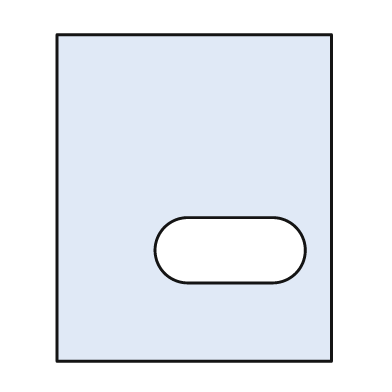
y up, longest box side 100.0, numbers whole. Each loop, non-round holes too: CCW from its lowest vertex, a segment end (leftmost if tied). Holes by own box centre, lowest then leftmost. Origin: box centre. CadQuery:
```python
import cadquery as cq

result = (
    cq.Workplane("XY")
    .moveTo(-42.0, -50.0)
    .lineTo(42.0, -50.0)
    .lineTo(42.0, 50.0)
    .lineTo(-42.0, 50.0)
    .close()
    .moveTo(-2.0, -26.0)
    .lineTo(24.0, -26.0)
    .threePointArc((34.0, -16.0), (24.0, -6.0))
    .lineTo(-2.0, -6.0)
    .threePointArc((-12.0, -16.0), (-2.0, -26.0))
    .close()
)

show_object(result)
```